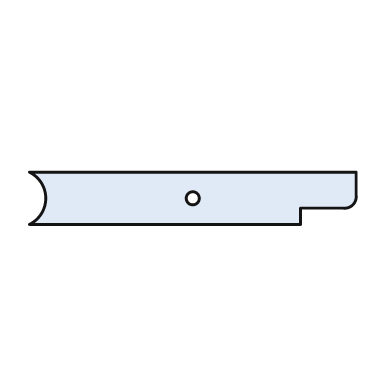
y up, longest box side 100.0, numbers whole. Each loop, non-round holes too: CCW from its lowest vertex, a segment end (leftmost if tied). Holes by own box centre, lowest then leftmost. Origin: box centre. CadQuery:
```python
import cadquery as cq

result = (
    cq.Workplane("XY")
    .moveTo(-50.0, -8.0)
    .lineTo(33.0, -8.0)
    .lineTo(33.0, -3.0)
    .lineTo(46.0, -3.0)
    .threePointArc((49.0, -2.0), (50.0, 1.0))
    .lineTo(50.0, 8.0)
    .lineTo(-50.0, 8.0)
    .threePointArc((-45.0, 0.0), (-50.0, -8.0))
    .close()
    .moveTo(0.0, 0.0)
    .circle(2.0)
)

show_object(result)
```